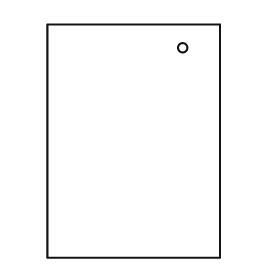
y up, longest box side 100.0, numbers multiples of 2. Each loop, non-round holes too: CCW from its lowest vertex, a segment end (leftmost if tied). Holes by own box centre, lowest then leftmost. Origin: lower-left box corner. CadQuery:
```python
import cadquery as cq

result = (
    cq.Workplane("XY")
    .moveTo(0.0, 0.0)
    .lineTo(74.0, 0.0)
    .lineTo(74.0, 100.0)
    .lineTo(0.0, 100.0)
    .close()
    .moveTo(58.0, 90.0)
    .circle(2.0)
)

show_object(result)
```